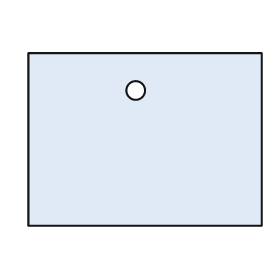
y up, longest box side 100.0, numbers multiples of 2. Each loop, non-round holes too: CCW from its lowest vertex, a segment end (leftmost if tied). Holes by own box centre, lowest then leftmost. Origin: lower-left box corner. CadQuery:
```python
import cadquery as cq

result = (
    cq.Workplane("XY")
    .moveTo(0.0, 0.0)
    .lineTo(100.0, 0.0)
    .lineTo(100.0, 74.0)
    .lineTo(0.0, 74.0)
    .close()
    .moveTo(46.0, 58.0)
    .circle(4.0)
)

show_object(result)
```